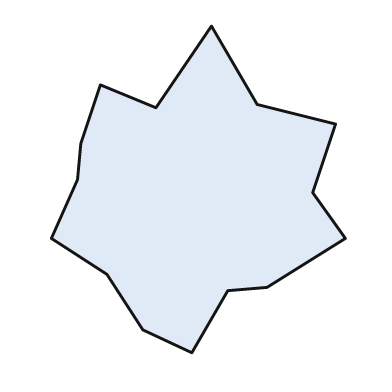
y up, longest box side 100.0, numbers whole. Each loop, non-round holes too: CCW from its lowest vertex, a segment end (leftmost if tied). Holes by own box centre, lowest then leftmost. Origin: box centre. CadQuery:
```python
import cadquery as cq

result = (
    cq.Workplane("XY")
    .moveTo(-2.0, -50.0)
    .lineTo(9.0, -31.0)
    .lineTo(21.0, -30.0)
    .lineTo(45.0, -15.0)
    .lineTo(35.0, -1.0)
    .lineTo(42.0, 20.0)
    .lineTo(18.0, 26.0)
    .lineTo(4.0, 50.0)
    .lineTo(-13.0, 25.0)
    .lineTo(-30.0, 32.0)
    .lineTo(-36.0, 14.0)
    .lineTo(-37.0, 3.0)
    .lineTo(-45.0, -15.0)
    .lineTo(-28.0, -26.0)
    .lineTo(-17.0, -43.0)
    .close()
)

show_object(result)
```